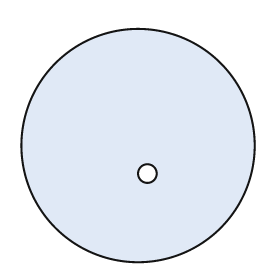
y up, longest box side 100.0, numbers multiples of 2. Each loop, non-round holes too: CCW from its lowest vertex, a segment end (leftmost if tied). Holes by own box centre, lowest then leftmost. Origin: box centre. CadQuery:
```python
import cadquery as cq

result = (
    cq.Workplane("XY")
    .moveTo(0.0, 0.0)
    .circle(50.0)
    .moveTo(4.0, -12.0)
    .circle(4.0)
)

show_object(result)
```